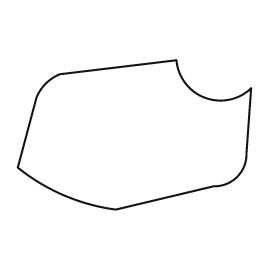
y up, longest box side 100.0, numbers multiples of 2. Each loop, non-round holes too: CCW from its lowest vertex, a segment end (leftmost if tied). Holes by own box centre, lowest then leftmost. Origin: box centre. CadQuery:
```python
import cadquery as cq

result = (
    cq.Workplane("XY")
    .moveTo(-8.0, -32.0)
    .lineTo(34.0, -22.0)
    .threePointArc((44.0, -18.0), (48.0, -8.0))
    .lineTo(50.0, 20.0)
    .threePointArc((30.0, 16.0), (18.0, 32.0))
    .lineTo(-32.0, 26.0)
    .threePointArc((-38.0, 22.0), (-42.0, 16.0))
    .lineTo(-50.0, -14.0)
    .threePointArc((-30.0, -26.0), (-8.0, -32.0))
    .close()
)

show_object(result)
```